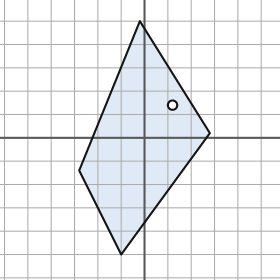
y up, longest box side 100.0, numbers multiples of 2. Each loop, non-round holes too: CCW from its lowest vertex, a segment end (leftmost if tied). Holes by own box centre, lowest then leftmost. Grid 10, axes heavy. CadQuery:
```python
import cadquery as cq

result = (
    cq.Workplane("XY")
    .moveTo(-10.0, -50.0)
    .lineTo(28.0, 2.0)
    .lineTo(-2.0, 50.0)
    .lineTo(-28.0, -14.0)
    .close()
    .moveTo(12.0, 14.0)
    .circle(2.0)
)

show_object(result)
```